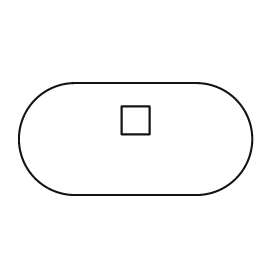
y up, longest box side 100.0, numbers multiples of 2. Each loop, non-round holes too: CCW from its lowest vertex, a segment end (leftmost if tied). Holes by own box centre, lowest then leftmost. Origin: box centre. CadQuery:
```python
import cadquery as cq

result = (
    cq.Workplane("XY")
    .moveTo(-26.0, -24.0)
    .lineTo(26.0, -24.0)
    .threePointArc((50.0, 0.0), (26.0, 24.0))
    .lineTo(-26.0, 24.0)
    .threePointArc((-50.0, 0.0), (-26.0, -24.0))
    .close()
    .moveTo(-6.0, 2.0)
    .lineTo(6.0, 2.0)
    .lineTo(6.0, 14.0)
    .lineTo(-6.0, 14.0)
    .close()
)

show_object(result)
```